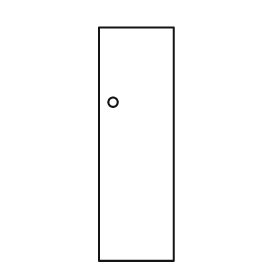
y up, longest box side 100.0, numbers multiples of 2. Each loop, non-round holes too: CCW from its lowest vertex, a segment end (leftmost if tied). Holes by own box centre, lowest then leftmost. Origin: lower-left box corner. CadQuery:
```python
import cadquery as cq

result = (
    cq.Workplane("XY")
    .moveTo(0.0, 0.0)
    .lineTo(32.0, 0.0)
    .lineTo(32.0, 100.0)
    .lineTo(0.0, 100.0)
    .close()
    .moveTo(6.0, 68.0)
    .circle(2.0)
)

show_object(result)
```